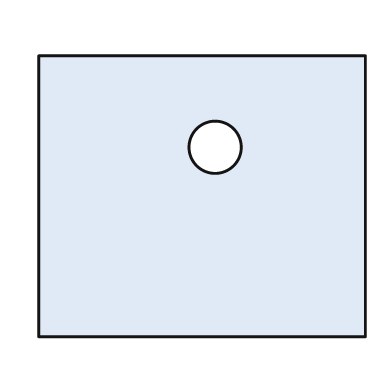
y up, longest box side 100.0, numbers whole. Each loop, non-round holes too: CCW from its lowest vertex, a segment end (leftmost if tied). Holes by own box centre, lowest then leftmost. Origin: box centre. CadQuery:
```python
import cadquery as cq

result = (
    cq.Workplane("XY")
    .moveTo(-50.0, -43.0)
    .lineTo(50.0, -43.0)
    .lineTo(50.0, 43.0)
    .lineTo(-50.0, 43.0)
    .close()
    .moveTo(4.0, 15.0)
    .circle(8.0)
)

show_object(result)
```